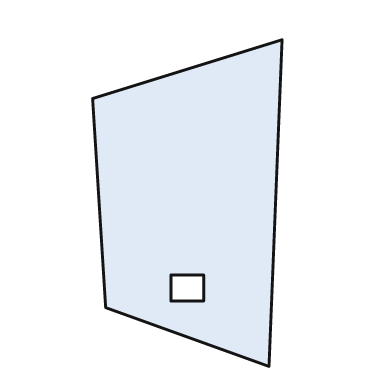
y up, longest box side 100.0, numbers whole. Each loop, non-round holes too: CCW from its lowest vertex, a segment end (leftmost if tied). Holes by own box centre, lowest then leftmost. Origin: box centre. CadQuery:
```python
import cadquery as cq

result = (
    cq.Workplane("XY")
    .moveTo(25.0, -50.0)
    .lineTo(29.0, 50.0)
    .lineTo(-29.0, 32.0)
    .lineTo(-25.0, -32.0)
    .close()
    .moveTo(-5.0, -30.0)
    .lineTo(5.0, -30.0)
    .lineTo(5.0, -22.0)
    .lineTo(-5.0, -22.0)
    .close()
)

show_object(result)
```